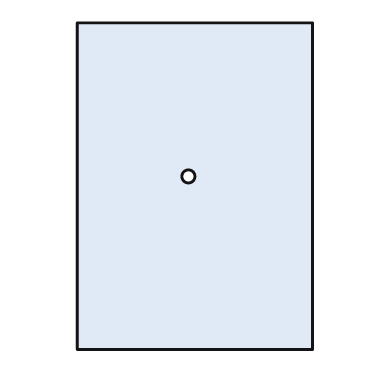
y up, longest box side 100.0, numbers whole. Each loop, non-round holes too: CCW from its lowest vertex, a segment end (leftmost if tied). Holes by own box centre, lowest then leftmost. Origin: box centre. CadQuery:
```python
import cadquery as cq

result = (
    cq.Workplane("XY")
    .moveTo(-36.0, -50.0)
    .lineTo(36.0, -50.0)
    .lineTo(36.0, 50.0)
    .lineTo(-36.0, 50.0)
    .close()
    .moveTo(-2.0, 3.0)
    .circle(2.0)
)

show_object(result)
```